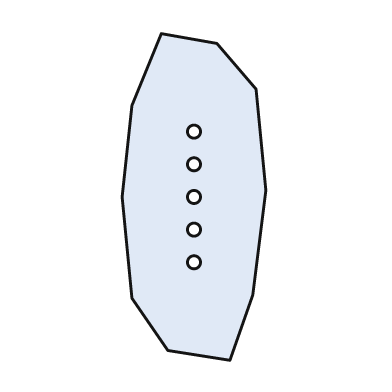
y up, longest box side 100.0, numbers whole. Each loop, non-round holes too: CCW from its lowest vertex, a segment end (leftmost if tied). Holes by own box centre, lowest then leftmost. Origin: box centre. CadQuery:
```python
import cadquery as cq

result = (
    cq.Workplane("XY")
    .moveTo(11.0, -50.0)
    .lineTo(18.0, -30.0)
    .lineTo(22.0, 2.0)
    .lineTo(19.0, 33.0)
    .lineTo(7.0, 47.0)
    .lineTo(-10.0, 50.0)
    .lineTo(-19.0, 28.0)
    .lineTo(-22.0, 0.0)
    .lineTo(-19.0, -31.0)
    .lineTo(-8.0, -47.0)
    .close()
    .moveTo(0.0, -20.0)
    .circle(2.0)
    .moveTo(0.0, -10.0)
    .circle(2.0)
    .moveTo(0.0, 0.0)
    .circle(2.0)
    .moveTo(0.0, 10.0)
    .circle(2.0)
    .moveTo(0.0, 20.0)
    .circle(2.0)
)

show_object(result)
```